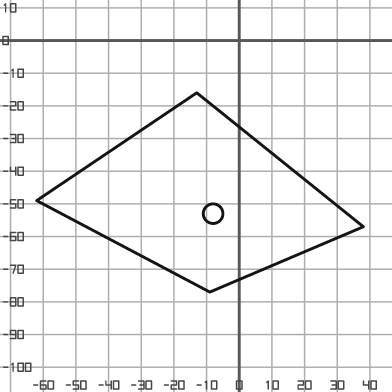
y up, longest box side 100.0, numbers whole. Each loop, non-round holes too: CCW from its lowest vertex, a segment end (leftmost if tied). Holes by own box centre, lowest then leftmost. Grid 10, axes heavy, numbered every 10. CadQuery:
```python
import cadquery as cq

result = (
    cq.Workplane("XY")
    .moveTo(-9.0, -77.0)
    .lineTo(38.0, -57.0)
    .lineTo(-13.0, -16.0)
    .lineTo(-62.0, -49.0)
    .close()
    .moveTo(-8.0, -53.0)
    .circle(3.0)
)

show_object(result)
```